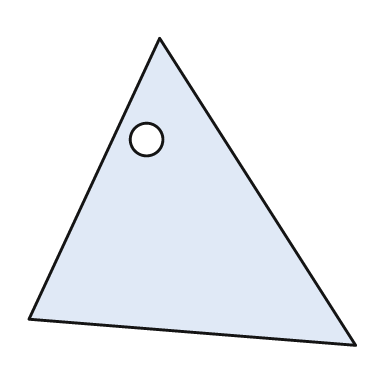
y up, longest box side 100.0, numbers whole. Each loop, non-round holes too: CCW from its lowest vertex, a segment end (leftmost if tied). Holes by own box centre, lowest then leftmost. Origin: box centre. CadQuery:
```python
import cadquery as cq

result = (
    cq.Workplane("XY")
    .moveTo(50.0, -47.0)
    .lineTo(-10.0, 47.0)
    .lineTo(-50.0, -39.0)
    .close()
    .moveTo(-14.0, 16.0)
    .circle(5.0)
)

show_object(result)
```